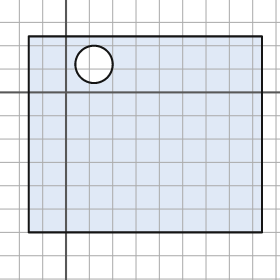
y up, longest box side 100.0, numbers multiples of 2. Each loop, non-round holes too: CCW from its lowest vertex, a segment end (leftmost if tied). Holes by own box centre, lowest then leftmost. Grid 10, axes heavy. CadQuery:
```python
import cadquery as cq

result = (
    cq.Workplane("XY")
    .moveTo(-16.0, -60.0)
    .lineTo(84.0, -60.0)
    .lineTo(84.0, 24.0)
    .lineTo(-16.0, 24.0)
    .close()
    .moveTo(12.0, 12.0)
    .circle(8.0)
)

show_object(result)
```